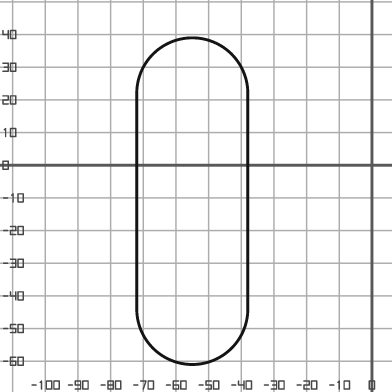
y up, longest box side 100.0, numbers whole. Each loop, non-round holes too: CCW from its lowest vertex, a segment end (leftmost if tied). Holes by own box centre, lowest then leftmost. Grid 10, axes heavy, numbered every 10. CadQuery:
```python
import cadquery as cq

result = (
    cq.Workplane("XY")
    .moveTo(-72.0, -44.0)
    .threePointArc((-55.0, -61.0), (-38.0, -44.0))
    .lineTo(-38.0, 22.0)
    .threePointArc((-55.0, 39.0), (-72.0, 22.0))
    .close()
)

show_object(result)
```